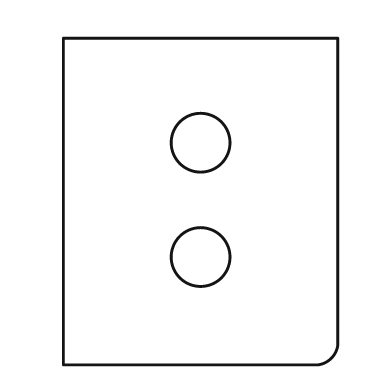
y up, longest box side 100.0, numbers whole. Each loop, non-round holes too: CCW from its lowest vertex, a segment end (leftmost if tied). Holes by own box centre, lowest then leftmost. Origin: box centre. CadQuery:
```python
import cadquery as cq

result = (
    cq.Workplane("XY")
    .moveTo(-42.0, -50.0)
    .lineTo(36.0, -50.0)
    .threePointArc((40.0, -48.0), (42.0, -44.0))
    .lineTo(42.0, 50.0)
    .lineTo(-42.0, 50.0)
    .close()
    .moveTo(0.0, -17.0)
    .circle(9.0)
    .moveTo(0.0, 18.0)
    .circle(9.0)
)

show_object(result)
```